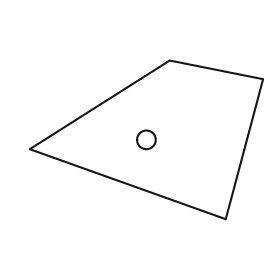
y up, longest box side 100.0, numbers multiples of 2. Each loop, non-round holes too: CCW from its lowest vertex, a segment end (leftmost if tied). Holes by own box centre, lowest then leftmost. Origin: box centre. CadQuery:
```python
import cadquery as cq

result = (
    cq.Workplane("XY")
    .moveTo(34.0, -34.0)
    .lineTo(50.0, 26.0)
    .lineTo(10.0, 34.0)
    .lineTo(-50.0, -4.0)
    .close()
    .moveTo(0.0, 0.0)
    .circle(4.0)
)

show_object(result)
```